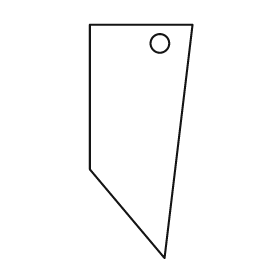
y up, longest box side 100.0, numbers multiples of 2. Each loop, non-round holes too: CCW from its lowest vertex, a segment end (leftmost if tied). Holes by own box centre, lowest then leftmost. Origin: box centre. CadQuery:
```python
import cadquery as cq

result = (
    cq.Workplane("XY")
    .moveTo(10.0, -50.0)
    .lineTo(22.0, 50.0)
    .lineTo(-22.0, 50.0)
    .lineTo(-22.0, -12.0)
    .close()
    .moveTo(8.0, 42.0)
    .circle(4.0)
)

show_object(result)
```